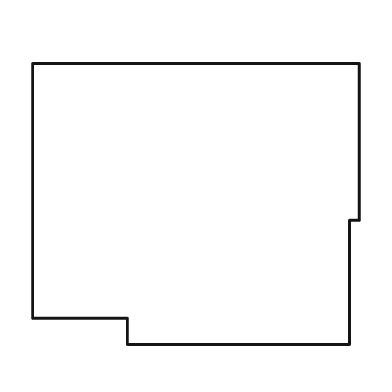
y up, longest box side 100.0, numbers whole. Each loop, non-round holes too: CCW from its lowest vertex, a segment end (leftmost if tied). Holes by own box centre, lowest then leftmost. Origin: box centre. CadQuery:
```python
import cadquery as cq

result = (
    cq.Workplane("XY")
    .moveTo(-21.0, -43.0)
    .lineTo(47.0, -43.0)
    .lineTo(47.0, -5.0)
    .lineTo(50.0, -5.0)
    .lineTo(50.0, 43.0)
    .lineTo(-50.0, 43.0)
    .lineTo(-50.0, -35.0)
    .lineTo(-21.0, -35.0)
    .close()
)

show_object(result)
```